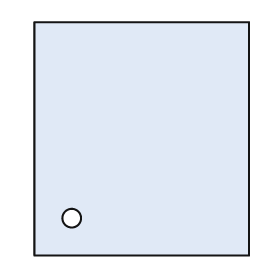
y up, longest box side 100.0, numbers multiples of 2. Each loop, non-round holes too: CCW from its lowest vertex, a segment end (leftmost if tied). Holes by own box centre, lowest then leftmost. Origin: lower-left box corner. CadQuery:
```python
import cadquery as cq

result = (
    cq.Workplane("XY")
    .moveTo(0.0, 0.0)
    .lineTo(92.0, 0.0)
    .lineTo(92.0, 100.0)
    .lineTo(0.0, 100.0)
    .close()
    .moveTo(16.0, 16.0)
    .circle(4.0)
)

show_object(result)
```